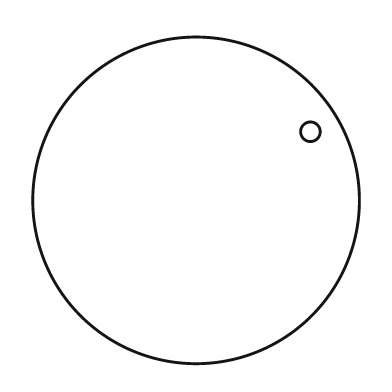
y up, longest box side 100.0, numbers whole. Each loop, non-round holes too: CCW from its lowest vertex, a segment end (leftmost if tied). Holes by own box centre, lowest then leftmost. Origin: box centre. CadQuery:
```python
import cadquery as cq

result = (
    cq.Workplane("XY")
    .moveTo(0.0, 0.0)
    .circle(50.0)
    .moveTo(35.0, 21.0)
    .circle(3.0)
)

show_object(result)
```